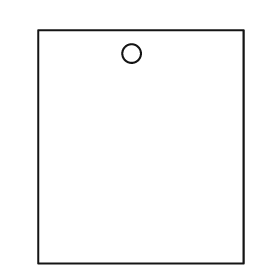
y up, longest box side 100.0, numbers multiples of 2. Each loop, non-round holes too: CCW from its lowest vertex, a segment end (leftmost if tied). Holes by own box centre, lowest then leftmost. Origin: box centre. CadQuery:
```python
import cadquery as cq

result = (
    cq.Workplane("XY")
    .moveTo(-44.0, -50.0)
    .lineTo(44.0, -50.0)
    .lineTo(44.0, 50.0)
    .lineTo(-44.0, 50.0)
    .close()
    .moveTo(-4.0, 40.0)
    .circle(4.0)
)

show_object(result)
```